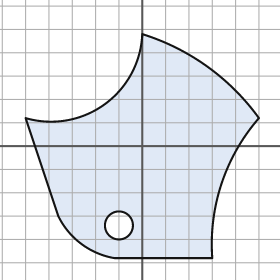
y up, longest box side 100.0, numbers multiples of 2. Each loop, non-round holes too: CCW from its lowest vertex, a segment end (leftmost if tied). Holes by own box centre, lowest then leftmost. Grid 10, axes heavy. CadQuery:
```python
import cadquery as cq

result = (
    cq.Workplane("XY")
    .moveTo(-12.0, -48.0)
    .lineTo(30.0, -48.0)
    .threePointArc((34.0, -16.0), (50.0, 12.0))
    .threePointArc((28.0, 34.0), (0.0, 48.0))
    .threePointArc((-16.0, 18.0), (-50.0, 12.0))
    .lineTo(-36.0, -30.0)
    .threePointArc((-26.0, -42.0), (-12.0, -48.0))
    .close()
    .moveTo(-10.0, -34.0)
    .circle(6.0)
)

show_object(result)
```